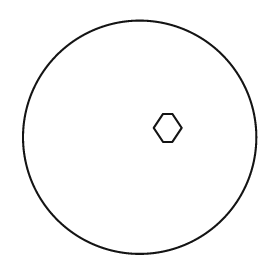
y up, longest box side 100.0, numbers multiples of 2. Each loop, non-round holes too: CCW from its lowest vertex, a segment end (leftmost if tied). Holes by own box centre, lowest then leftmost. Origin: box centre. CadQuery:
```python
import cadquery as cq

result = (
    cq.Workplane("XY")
    .moveTo(0.0, 0.0)
    .circle(50.0)
    .moveTo(10.0, -2.0)
    .lineTo(14.0, -2.0)
    .lineTo(18.0, 4.0)
    .lineTo(14.0, 10.0)
    .lineTo(10.0, 10.0)
    .lineTo(6.0, 4.0)
    .close()
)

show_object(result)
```